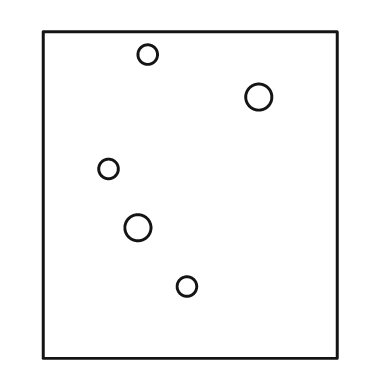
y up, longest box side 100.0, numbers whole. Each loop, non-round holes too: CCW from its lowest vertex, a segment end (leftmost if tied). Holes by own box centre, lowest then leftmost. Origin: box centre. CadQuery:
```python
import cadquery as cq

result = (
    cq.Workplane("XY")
    .moveTo(-45.0, -50.0)
    .lineTo(45.0, -50.0)
    .lineTo(45.0, 50.0)
    .lineTo(-45.0, 50.0)
    .close()
    .moveTo(-1.0, -28.0)
    .circle(3.0)
    .moveTo(-16.0, -10.0)
    .circle(4.0)
    .moveTo(-25.0, 8.0)
    .circle(3.0)
    .moveTo(21.0, 30.0)
    .circle(4.0)
    .moveTo(-13.0, 43.0)
    .circle(3.0)
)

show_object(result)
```